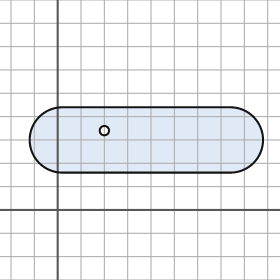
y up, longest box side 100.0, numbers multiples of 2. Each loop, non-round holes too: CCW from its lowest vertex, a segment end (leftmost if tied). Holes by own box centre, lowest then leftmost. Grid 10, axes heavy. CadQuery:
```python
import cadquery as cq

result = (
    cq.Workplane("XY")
    .moveTo(2.0, 16.0)
    .lineTo(74.0, 16.0)
    .threePointArc((88.0, 30.0), (74.0, 44.0))
    .lineTo(2.0, 44.0)
    .threePointArc((-12.0, 30.0), (2.0, 16.0))
    .close()
    .moveTo(20.0, 34.0)
    .circle(2.0)
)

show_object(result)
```